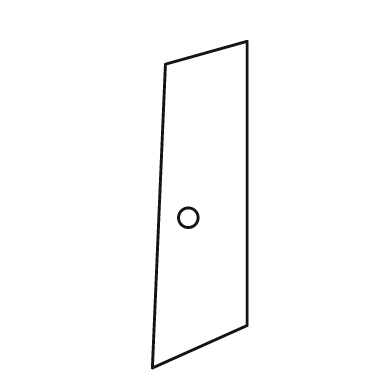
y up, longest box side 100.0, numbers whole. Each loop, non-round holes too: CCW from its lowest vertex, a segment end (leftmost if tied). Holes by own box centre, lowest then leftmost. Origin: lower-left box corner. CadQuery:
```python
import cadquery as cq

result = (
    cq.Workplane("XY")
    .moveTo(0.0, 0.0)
    .lineTo(29.0, 13.0)
    .lineTo(29.0, 100.0)
    .lineTo(4.0, 93.0)
    .close()
    .moveTo(11.0, 46.0)
    .circle(3.0)
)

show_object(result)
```